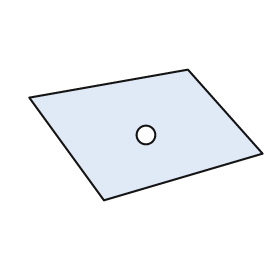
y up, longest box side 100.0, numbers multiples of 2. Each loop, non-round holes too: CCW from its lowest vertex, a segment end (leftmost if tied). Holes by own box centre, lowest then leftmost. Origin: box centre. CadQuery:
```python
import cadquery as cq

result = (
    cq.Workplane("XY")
    .moveTo(-18.0, -28.0)
    .lineTo(50.0, -8.0)
    .lineTo(18.0, 28.0)
    .lineTo(-50.0, 16.0)
    .close()
    .moveTo(0.0, 0.0)
    .circle(4.0)
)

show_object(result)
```